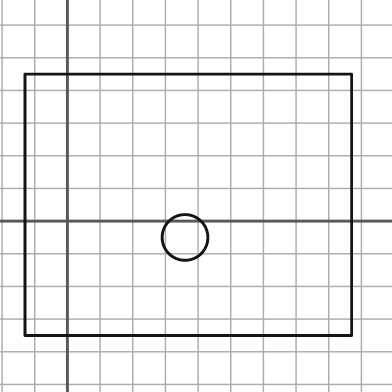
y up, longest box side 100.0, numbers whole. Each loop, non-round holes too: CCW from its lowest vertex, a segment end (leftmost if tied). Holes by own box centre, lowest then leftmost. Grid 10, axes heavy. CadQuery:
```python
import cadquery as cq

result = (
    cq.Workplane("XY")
    .moveTo(-13.0, -35.0)
    .lineTo(87.0, -35.0)
    .lineTo(87.0, 45.0)
    .lineTo(-13.0, 45.0)
    .close()
    .moveTo(36.0, -5.0)
    .circle(7.0)
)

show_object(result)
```